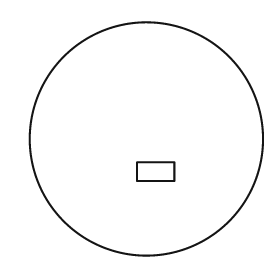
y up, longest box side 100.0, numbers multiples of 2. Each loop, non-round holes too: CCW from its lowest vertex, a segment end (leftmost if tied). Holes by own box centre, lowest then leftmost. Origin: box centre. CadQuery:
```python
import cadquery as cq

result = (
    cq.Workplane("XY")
    .moveTo(0.0, 0.0)
    .circle(50.0)
    .moveTo(-4.0, -18.0)
    .lineTo(12.0, -18.0)
    .lineTo(12.0, -10.0)
    .lineTo(-4.0, -10.0)
    .close()
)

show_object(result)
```